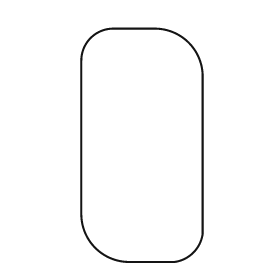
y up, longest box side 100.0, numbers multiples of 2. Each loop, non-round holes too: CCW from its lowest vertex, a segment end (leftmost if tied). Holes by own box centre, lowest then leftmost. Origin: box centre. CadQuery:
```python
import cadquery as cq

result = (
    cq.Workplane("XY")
    .moveTo(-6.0, -50.0)
    .lineTo(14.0, -50.0)
    .threePointArc((22.0, -46.0), (26.0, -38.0))
    .lineTo(26.0, 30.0)
    .threePointArc((20.0, 44.0), (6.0, 50.0))
    .lineTo(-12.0, 50.0)
    .threePointArc((-22.0, 46.0), (-26.0, 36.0))
    .lineTo(-26.0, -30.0)
    .threePointArc((-20.0, -44.0), (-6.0, -50.0))
    .close()
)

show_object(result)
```